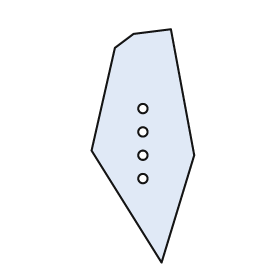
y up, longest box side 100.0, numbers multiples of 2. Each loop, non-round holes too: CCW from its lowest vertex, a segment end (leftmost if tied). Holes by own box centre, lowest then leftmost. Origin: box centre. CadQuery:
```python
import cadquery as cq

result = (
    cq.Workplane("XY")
    .moveTo(8.0, -50.0)
    .lineTo(22.0, -4.0)
    .lineTo(12.0, 50.0)
    .lineTo(-4.0, 48.0)
    .lineTo(-12.0, 42.0)
    .lineTo(-22.0, -2.0)
    .close()
    .moveTo(0.0, -14.0)
    .circle(2.0)
    .moveTo(0.0, -4.0)
    .circle(2.0)
    .moveTo(0.0, 6.0)
    .circle(2.0)
    .moveTo(0.0, 16.0)
    .circle(2.0)
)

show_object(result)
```